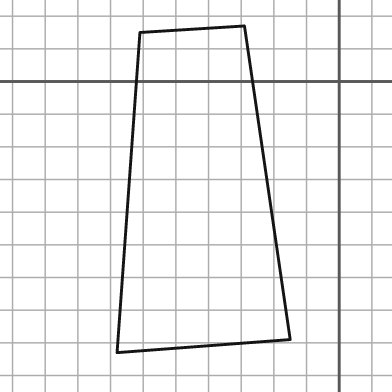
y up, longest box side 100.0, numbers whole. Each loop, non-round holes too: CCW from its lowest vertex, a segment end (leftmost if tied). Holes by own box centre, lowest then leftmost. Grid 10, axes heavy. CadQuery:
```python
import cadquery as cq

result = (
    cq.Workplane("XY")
    .moveTo(-68.0, -83.0)
    .lineTo(-15.0, -79.0)
    .lineTo(-29.0, 17.0)
    .lineTo(-61.0, 15.0)
    .close()
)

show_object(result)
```